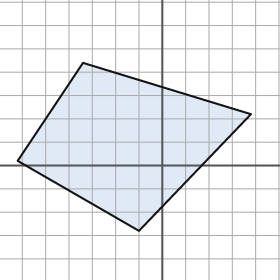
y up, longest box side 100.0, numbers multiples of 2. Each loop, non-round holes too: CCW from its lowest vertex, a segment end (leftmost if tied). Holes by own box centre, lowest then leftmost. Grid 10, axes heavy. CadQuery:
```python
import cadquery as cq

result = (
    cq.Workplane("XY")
    .moveTo(-10.0, -28.0)
    .lineTo(38.0, 22.0)
    .lineTo(-34.0, 44.0)
    .lineTo(-62.0, 2.0)
    .close()
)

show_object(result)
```